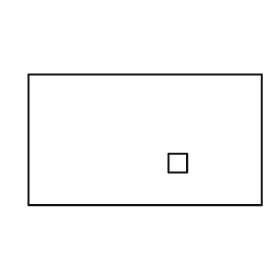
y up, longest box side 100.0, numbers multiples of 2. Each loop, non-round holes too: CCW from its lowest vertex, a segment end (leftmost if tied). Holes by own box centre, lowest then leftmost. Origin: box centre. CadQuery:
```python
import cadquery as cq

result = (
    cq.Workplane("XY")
    .moveTo(-50.0, -28.0)
    .lineTo(50.0, -28.0)
    .lineTo(50.0, 28.0)
    .lineTo(-50.0, 28.0)
    .close()
    .moveTo(10.0, -14.0)
    .lineTo(18.0, -14.0)
    .lineTo(18.0, -6.0)
    .lineTo(10.0, -6.0)
    .close()
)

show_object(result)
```